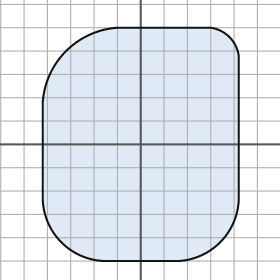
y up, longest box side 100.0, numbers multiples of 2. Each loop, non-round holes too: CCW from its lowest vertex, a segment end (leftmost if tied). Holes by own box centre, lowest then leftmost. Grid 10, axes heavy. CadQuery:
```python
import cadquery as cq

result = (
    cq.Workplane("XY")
    .moveTo(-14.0, -50.0)
    .lineTo(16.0, -50.0)
    .threePointArc((34.0, -42.0), (42.0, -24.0))
    .lineTo(42.0, 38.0)
    .threePointArc((38.0, 46.0), (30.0, 50.0))
    .lineTo(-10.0, 50.0)
    .threePointArc((-32.0, 40.0), (-42.0, 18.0))
    .lineTo(-42.0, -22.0)
    .threePointArc((-34.0, -42.0), (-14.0, -50.0))
    .close()
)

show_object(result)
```